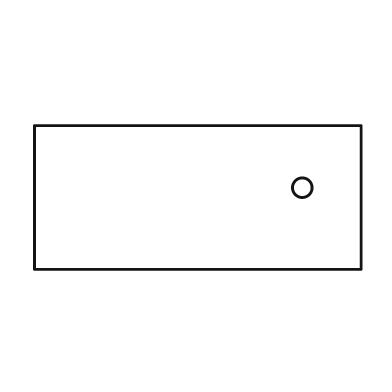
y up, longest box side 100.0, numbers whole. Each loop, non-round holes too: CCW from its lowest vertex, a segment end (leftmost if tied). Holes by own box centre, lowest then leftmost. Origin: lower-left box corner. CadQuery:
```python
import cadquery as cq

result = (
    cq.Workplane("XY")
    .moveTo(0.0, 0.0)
    .lineTo(100.0, 0.0)
    .lineTo(100.0, 44.0)
    .lineTo(0.0, 44.0)
    .close()
    .moveTo(82.0, 25.0)
    .circle(3.0)
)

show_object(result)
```